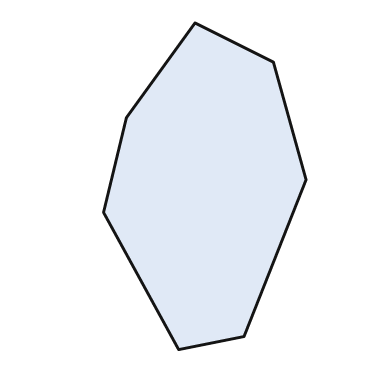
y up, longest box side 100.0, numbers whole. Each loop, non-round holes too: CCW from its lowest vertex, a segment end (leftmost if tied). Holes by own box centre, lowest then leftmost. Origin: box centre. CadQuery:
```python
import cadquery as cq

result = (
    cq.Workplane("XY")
    .moveTo(-8.0, -50.0)
    .lineTo(12.0, -46.0)
    .lineTo(31.0, 2.0)
    .lineTo(21.0, 38.0)
    .lineTo(-3.0, 50.0)
    .lineTo(-24.0, 21.0)
    .lineTo(-31.0, -8.0)
    .close()
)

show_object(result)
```